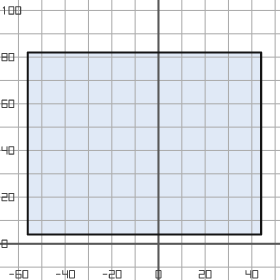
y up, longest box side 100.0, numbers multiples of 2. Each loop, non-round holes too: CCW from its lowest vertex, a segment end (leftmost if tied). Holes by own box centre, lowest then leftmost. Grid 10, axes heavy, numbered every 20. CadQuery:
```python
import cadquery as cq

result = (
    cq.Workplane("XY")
    .moveTo(-56.0, 4.0)
    .lineTo(44.0, 4.0)
    .lineTo(44.0, 82.0)
    .lineTo(-56.0, 82.0)
    .close()
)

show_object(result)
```